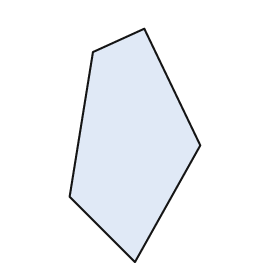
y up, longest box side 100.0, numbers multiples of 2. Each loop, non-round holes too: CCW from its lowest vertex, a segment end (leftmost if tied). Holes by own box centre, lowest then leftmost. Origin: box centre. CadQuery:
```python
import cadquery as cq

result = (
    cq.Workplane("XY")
    .moveTo(0.0, -50.0)
    .lineTo(28.0, 0.0)
    .lineTo(4.0, 50.0)
    .lineTo(-18.0, 40.0)
    .lineTo(-28.0, -22.0)
    .close()
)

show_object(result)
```